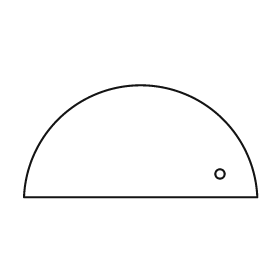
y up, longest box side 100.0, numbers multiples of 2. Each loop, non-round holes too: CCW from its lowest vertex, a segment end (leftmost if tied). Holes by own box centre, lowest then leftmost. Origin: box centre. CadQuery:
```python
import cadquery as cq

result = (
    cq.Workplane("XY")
    .moveTo(-50.0, -24.0)
    .lineTo(50.0, -24.0)
    .threePointArc((0.0, 24.0), (-50.0, -24.0))
    .close()
    .moveTo(34.0, -14.0)
    .circle(2.0)
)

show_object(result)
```